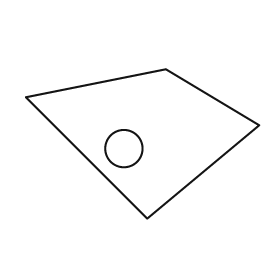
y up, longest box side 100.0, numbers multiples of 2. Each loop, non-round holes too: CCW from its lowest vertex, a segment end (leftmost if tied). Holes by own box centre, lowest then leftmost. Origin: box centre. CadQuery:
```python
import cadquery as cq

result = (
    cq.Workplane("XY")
    .moveTo(2.0, -32.0)
    .lineTo(50.0, 8.0)
    .lineTo(10.0, 32.0)
    .lineTo(-50.0, 20.0)
    .close()
    .moveTo(-8.0, -2.0)
    .circle(8.0)
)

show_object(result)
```